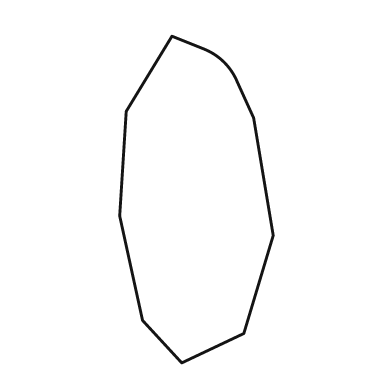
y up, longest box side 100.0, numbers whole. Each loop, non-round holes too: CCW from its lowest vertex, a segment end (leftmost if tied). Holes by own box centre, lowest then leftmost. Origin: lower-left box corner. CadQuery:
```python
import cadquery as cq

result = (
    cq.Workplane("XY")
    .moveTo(19.0, 0.0)
    .lineTo(38.0, 9.0)
    .lineTo(47.0, 39.0)
    .lineTo(41.0, 75.0)
    .lineTo(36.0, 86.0)
    .threePointArc((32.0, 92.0), (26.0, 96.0))
    .lineTo(16.0, 100.0)
    .lineTo(2.0, 77.0)
    .lineTo(0.0, 45.0)
    .lineTo(7.0, 13.0)
    .close()
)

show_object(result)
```